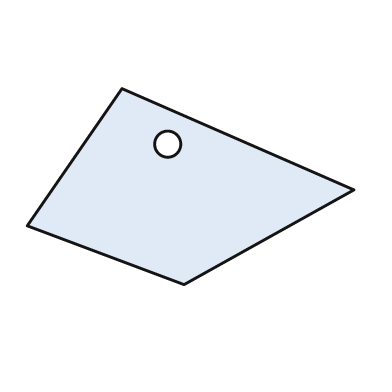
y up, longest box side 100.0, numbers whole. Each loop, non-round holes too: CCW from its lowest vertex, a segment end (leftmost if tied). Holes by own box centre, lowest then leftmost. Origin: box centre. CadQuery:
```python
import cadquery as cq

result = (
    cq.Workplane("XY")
    .moveTo(-2.0, -30.0)
    .lineTo(50.0, -1.0)
    .lineTo(-21.0, 30.0)
    .lineTo(-50.0, -12.0)
    .close()
    .moveTo(-7.0, 13.0)
    .circle(4.0)
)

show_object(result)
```